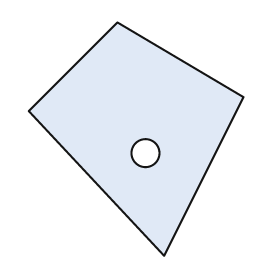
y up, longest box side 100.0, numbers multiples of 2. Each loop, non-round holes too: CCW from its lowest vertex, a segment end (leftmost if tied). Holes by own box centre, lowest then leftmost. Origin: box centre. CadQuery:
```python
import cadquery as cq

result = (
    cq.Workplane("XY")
    .moveTo(12.0, -50.0)
    .lineTo(46.0, 18.0)
    .lineTo(-8.0, 50.0)
    .lineTo(-46.0, 12.0)
    .close()
    .moveTo(4.0, -6.0)
    .circle(6.0)
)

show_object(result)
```